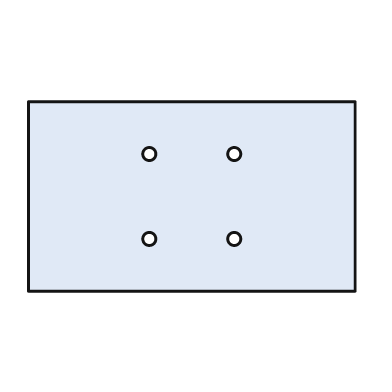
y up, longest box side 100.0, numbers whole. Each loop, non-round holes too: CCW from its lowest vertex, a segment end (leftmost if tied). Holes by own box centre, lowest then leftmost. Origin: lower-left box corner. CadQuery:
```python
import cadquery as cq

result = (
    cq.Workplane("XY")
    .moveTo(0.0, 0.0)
    .lineTo(100.0, 0.0)
    .lineTo(100.0, 58.0)
    .lineTo(0.0, 58.0)
    .close()
    .moveTo(37.0, 16.0)
    .circle(2.0)
    .moveTo(63.0, 16.0)
    .circle(2.0)
    .moveTo(37.0, 42.0)
    .circle(2.0)
    .moveTo(63.0, 42.0)
    .circle(2.0)
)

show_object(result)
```